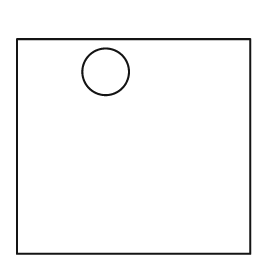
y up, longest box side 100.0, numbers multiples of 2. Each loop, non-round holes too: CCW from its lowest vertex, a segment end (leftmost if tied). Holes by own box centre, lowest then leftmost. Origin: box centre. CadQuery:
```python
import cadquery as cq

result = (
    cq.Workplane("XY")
    .moveTo(-50.0, -46.0)
    .lineTo(50.0, -46.0)
    .lineTo(50.0, 46.0)
    .lineTo(-50.0, 46.0)
    .close()
    .moveTo(-12.0, 32.0)
    .circle(10.0)
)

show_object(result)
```